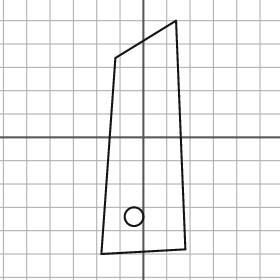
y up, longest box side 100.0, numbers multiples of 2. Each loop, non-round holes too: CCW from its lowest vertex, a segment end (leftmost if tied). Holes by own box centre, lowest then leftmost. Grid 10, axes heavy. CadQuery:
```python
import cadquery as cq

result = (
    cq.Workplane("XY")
    .moveTo(-18.0, -50.0)
    .lineTo(18.0, -48.0)
    .lineTo(14.0, 50.0)
    .lineTo(-12.0, 34.0)
    .close()
    .moveTo(-4.0, -34.0)
    .circle(4.0)
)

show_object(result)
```